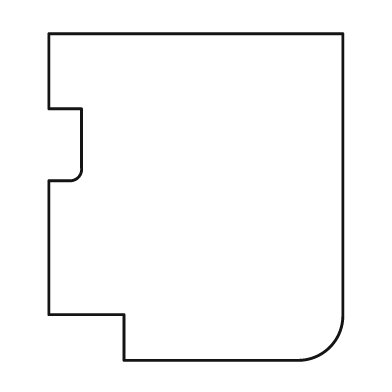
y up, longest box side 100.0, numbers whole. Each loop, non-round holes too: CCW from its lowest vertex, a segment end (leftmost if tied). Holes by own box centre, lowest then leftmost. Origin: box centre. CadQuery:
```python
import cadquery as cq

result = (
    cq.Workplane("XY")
    .moveTo(-22.0, -50.0)
    .lineTo(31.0, -50.0)
    .threePointArc((41.0, -46.0), (45.0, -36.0))
    .lineTo(45.0, 50.0)
    .lineTo(-45.0, 50.0)
    .lineTo(-45.0, 27.0)
    .lineTo(-35.0, 27.0)
    .lineTo(-35.0, 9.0)
    .threePointArc((-36.0, 6.0), (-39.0, 5.0))
    .lineTo(-45.0, 5.0)
    .lineTo(-45.0, -36.0)
    .lineTo(-22.0, -36.0)
    .close()
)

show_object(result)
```